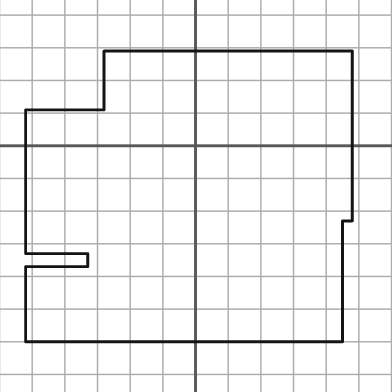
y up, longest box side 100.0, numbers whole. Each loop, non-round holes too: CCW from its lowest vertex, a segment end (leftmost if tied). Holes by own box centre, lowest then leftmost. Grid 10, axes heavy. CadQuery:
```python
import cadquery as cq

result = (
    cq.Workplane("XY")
    .moveTo(-52.0, -60.0)
    .lineTo(45.0, -60.0)
    .lineTo(45.0, -23.0)
    .lineTo(48.0, -23.0)
    .lineTo(48.0, 29.0)
    .lineTo(-28.0, 29.0)
    .lineTo(-28.0, 11.0)
    .lineTo(-52.0, 11.0)
    .lineTo(-52.0, -33.0)
    .lineTo(-33.0, -33.0)
    .lineTo(-33.0, -37.0)
    .lineTo(-52.0, -37.0)
    .close()
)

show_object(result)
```